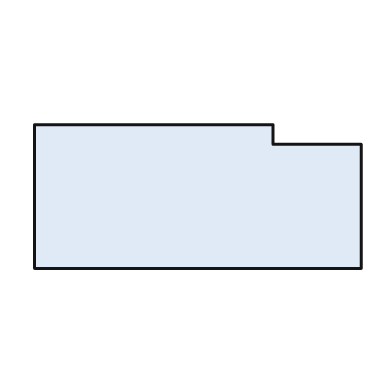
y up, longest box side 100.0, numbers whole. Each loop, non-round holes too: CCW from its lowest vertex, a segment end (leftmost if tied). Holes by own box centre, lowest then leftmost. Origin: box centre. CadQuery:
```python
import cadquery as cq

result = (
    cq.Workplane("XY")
    .moveTo(-50.0, -22.0)
    .lineTo(50.0, -22.0)
    .lineTo(50.0, 16.0)
    .lineTo(23.0, 16.0)
    .lineTo(23.0, 22.0)
    .lineTo(-50.0, 22.0)
    .close()
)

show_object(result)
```